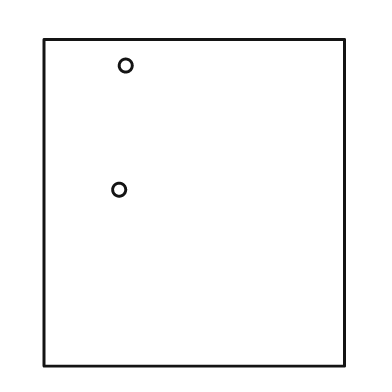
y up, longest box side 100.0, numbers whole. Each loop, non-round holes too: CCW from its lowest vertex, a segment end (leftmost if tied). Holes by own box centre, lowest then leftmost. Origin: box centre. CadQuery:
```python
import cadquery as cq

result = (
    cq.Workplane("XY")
    .moveTo(-46.0, -50.0)
    .lineTo(46.0, -50.0)
    .lineTo(46.0, 50.0)
    .lineTo(-46.0, 50.0)
    .close()
    .moveTo(-23.0, 4.0)
    .circle(2.0)
    .moveTo(-21.0, 42.0)
    .circle(2.0)
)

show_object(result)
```